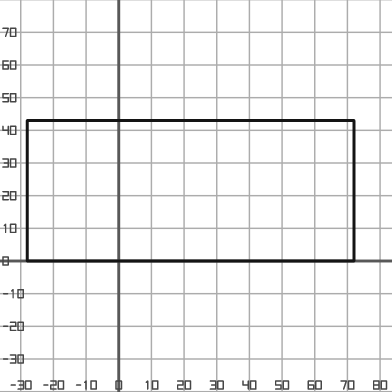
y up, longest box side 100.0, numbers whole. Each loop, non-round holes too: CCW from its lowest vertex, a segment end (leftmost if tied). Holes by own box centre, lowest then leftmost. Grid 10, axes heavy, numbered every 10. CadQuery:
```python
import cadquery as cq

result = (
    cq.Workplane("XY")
    .moveTo(-28.0, 0.0)
    .lineTo(72.0, 0.0)
    .lineTo(72.0, 43.0)
    .lineTo(-28.0, 43.0)
    .close()
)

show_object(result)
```